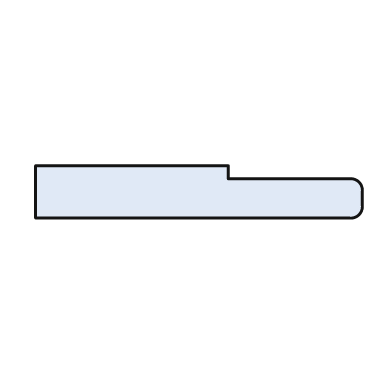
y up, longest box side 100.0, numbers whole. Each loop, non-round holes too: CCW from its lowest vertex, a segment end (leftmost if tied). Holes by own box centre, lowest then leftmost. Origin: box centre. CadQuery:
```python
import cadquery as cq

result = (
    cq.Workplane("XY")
    .moveTo(-50.0, -8.0)
    .lineTo(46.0, -8.0)
    .threePointArc((49.0, -7.0), (50.0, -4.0))
    .lineTo(50.0, 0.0)
    .threePointArc((49.0, 3.0), (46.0, 4.0))
    .lineTo(9.0, 4.0)
    .lineTo(9.0, 8.0)
    .lineTo(-50.0, 8.0)
    .close()
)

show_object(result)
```